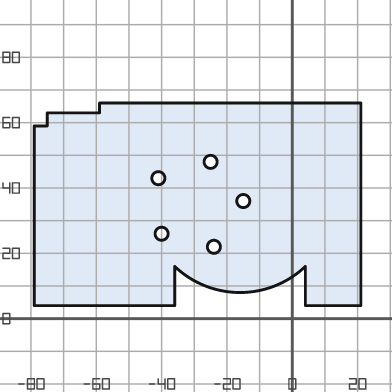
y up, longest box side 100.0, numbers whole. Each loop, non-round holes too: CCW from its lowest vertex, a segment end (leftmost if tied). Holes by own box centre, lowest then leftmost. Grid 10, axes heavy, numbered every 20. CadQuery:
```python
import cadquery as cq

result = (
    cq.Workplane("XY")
    .moveTo(-79.0, 4.0)
    .lineTo(-36.0, 4.0)
    .lineTo(-36.0, 16.0)
    .threePointArc((-16.0, 8.0), (4.0, 16.0))
    .lineTo(4.0, 4.0)
    .lineTo(21.0, 4.0)
    .lineTo(21.0, 66.0)
    .lineTo(-59.0, 66.0)
    .lineTo(-59.0, 63.0)
    .lineTo(-75.0, 63.0)
    .lineTo(-75.0, 59.0)
    .lineTo(-79.0, 59.0)
    .close()
    .moveTo(-24.0, 22.0)
    .circle(2.0)
    .moveTo(-40.0, 26.0)
    .circle(2.0)
    .moveTo(-15.0, 36.0)
    .circle(2.0)
    .moveTo(-41.0, 43.0)
    .circle(2.0)
    .moveTo(-25.0, 48.0)
    .circle(2.0)
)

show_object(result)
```